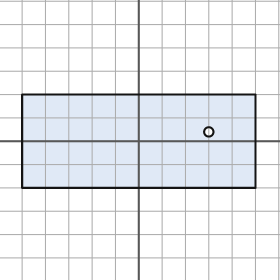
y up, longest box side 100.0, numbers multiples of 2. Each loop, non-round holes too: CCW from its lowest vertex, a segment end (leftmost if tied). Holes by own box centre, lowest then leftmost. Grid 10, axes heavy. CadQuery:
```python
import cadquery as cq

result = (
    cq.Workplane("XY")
    .moveTo(-50.0, -20.0)
    .lineTo(50.0, -20.0)
    .lineTo(50.0, 20.0)
    .lineTo(-50.0, 20.0)
    .close()
    .moveTo(30.0, 4.0)
    .circle(2.0)
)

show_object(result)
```